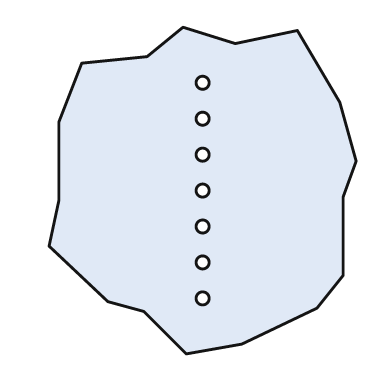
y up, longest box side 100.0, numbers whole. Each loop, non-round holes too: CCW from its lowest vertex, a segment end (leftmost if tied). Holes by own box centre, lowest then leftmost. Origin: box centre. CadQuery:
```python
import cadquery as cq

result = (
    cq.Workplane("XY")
    .moveTo(-5.0, -50.0)
    .lineTo(12.0, -47.0)
    .lineTo(35.0, -36.0)
    .lineTo(43.0, -26.0)
    .lineTo(43.0, -2.0)
    .lineTo(47.0, 9.0)
    .lineTo(42.0, 27.0)
    .lineTo(29.0, 49.0)
    .lineTo(10.0, 45.0)
    .lineTo(-6.0, 50.0)
    .lineTo(-17.0, 41.0)
    .lineTo(-37.0, 39.0)
    .lineTo(-44.0, 21.0)
    .lineTo(-44.0, -3.0)
    .lineTo(-47.0, -17.0)
    .lineTo(-29.0, -34.0)
    .lineTo(-18.0, -37.0)
    .close()
    .moveTo(0.0, -33.0)
    .circle(2.0)
    .moveTo(0.0, -22.0)
    .circle(2.0)
    .moveTo(0.0, -11.0)
    .circle(2.0)
    .moveTo(0.0, 0.0)
    .circle(2.0)
    .moveTo(0.0, 11.0)
    .circle(2.0)
    .moveTo(0.0, 22.0)
    .circle(2.0)
    .moveTo(0.0, 33.0)
    .circle(2.0)
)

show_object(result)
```